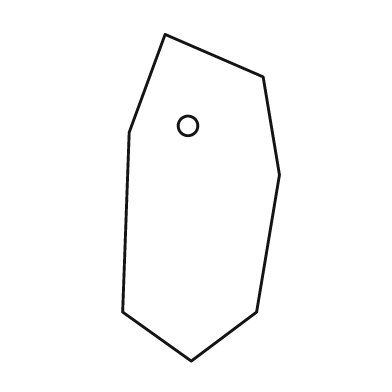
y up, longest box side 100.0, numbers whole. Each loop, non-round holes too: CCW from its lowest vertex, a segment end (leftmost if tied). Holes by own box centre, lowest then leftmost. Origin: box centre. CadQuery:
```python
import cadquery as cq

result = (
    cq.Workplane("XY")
    .moveTo(-3.0, -50.0)
    .lineTo(17.0, -35.0)
    .lineTo(24.0, 7.0)
    .lineTo(19.0, 37.0)
    .lineTo(-11.0, 50.0)
    .lineTo(-22.0, 20.0)
    .lineTo(-24.0, -35.0)
    .close()
    .moveTo(-4.0, 22.0)
    .circle(3.0)
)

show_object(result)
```